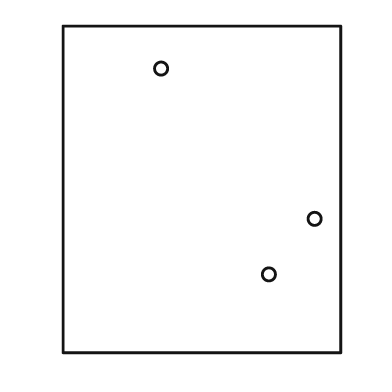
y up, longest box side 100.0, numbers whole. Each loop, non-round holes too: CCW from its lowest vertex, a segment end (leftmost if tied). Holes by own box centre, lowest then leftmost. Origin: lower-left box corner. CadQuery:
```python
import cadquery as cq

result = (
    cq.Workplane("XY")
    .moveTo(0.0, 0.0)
    .lineTo(85.0, 0.0)
    .lineTo(85.0, 100.0)
    .lineTo(0.0, 100.0)
    .close()
    .moveTo(63.0, 24.0)
    .circle(2.0)
    .moveTo(77.0, 41.0)
    .circle(2.0)
    .moveTo(30.0, 87.0)
    .circle(2.0)
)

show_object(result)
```